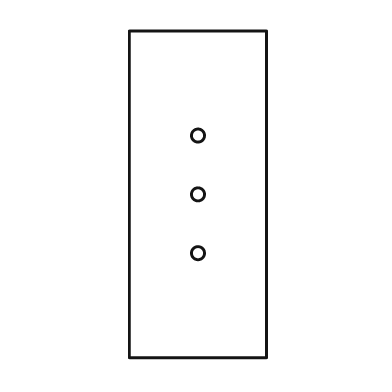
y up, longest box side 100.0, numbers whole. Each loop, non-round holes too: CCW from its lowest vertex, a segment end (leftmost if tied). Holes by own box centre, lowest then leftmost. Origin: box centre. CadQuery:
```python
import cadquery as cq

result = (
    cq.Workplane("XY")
    .moveTo(-21.0, -50.0)
    .lineTo(21.0, -50.0)
    .lineTo(21.0, 50.0)
    .lineTo(-21.0, 50.0)
    .close()
    .moveTo(0.0, -18.0)
    .circle(2.0)
    .moveTo(0.0, 0.0)
    .circle(2.0)
    .moveTo(0.0, 18.0)
    .circle(2.0)
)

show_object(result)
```